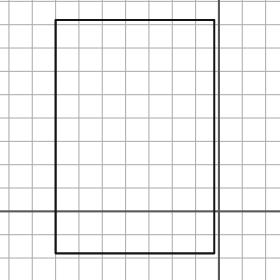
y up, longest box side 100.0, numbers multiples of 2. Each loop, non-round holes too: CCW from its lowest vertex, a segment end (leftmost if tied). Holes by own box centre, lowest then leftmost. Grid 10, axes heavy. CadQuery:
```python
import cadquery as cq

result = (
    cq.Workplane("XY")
    .moveTo(-70.0, -18.0)
    .lineTo(-2.0, -18.0)
    .lineTo(-2.0, 82.0)
    .lineTo(-70.0, 82.0)
    .close()
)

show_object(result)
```